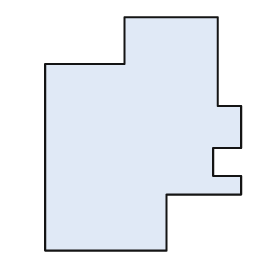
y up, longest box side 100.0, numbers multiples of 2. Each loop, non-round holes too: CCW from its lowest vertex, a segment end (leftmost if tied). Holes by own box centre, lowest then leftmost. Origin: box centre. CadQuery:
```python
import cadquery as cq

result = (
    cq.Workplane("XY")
    .moveTo(-42.0, -50.0)
    .lineTo(10.0, -50.0)
    .lineTo(10.0, -26.0)
    .lineTo(42.0, -26.0)
    .lineTo(42.0, -18.0)
    .lineTo(30.0, -18.0)
    .lineTo(30.0, -6.0)
    .lineTo(42.0, -6.0)
    .lineTo(42.0, 12.0)
    .lineTo(32.0, 12.0)
    .lineTo(32.0, 50.0)
    .lineTo(-8.0, 50.0)
    .lineTo(-8.0, 30.0)
    .lineTo(-42.0, 30.0)
    .close()
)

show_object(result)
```